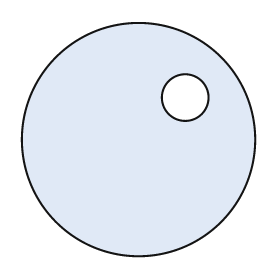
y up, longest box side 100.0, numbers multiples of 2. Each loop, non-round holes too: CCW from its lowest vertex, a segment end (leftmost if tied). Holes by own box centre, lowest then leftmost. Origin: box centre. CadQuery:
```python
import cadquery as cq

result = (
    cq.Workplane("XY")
    .moveTo(0.0, 0.0)
    .circle(50.0)
    .moveTo(20.0, 18.0)
    .circle(10.0)
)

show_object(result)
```